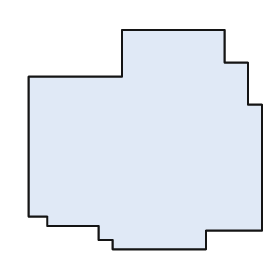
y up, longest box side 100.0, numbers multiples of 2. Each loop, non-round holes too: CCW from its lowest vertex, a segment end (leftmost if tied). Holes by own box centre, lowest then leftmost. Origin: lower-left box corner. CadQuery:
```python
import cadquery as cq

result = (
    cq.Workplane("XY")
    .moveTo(36.0, 0.0)
    .lineTo(76.0, 0.0)
    .lineTo(76.0, 8.0)
    .lineTo(100.0, 8.0)
    .lineTo(100.0, 62.0)
    .lineTo(94.0, 62.0)
    .lineTo(94.0, 80.0)
    .lineTo(84.0, 80.0)
    .lineTo(84.0, 94.0)
    .lineTo(40.0, 94.0)
    .lineTo(40.0, 74.0)
    .lineTo(0.0, 74.0)
    .lineTo(0.0, 14.0)
    .lineTo(8.0, 14.0)
    .lineTo(8.0, 10.0)
    .lineTo(30.0, 10.0)
    .lineTo(30.0, 4.0)
    .lineTo(36.0, 4.0)
    .close()
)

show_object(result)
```